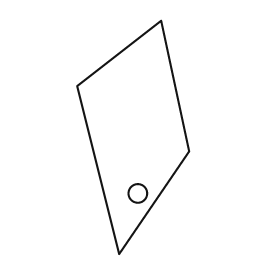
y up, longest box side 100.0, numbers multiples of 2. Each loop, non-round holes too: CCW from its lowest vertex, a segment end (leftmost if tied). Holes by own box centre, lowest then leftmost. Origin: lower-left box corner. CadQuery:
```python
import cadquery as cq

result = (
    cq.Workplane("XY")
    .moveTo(18.0, 0.0)
    .lineTo(48.0, 44.0)
    .lineTo(36.0, 100.0)
    .lineTo(0.0, 72.0)
    .close()
    .moveTo(26.0, 26.0)
    .circle(4.0)
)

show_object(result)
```